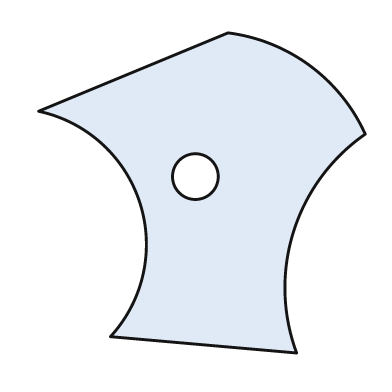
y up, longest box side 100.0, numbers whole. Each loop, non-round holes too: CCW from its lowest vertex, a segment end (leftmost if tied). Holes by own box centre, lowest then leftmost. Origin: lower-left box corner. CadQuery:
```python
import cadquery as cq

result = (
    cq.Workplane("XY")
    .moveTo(79.0, 0.0)
    .threePointArc((78.0, 37.0), (100.0, 67.0))
    .threePointArc((83.0, 88.0), (58.0, 98.0))
    .lineTo(0.0, 74.0)
    .threePointArc((31.0, 46.0), (22.0, 5.0))
    .close()
    .moveTo(48.0, 54.0)
    .circle(7.0)
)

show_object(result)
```